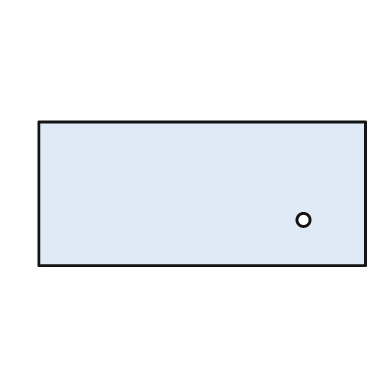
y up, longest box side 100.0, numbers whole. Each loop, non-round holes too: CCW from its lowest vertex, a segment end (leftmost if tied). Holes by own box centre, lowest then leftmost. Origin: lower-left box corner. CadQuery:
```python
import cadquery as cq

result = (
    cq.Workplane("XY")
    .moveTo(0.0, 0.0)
    .lineTo(100.0, 0.0)
    .lineTo(100.0, 44.0)
    .lineTo(0.0, 44.0)
    .close()
    .moveTo(81.0, 14.0)
    .circle(2.0)
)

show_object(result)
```